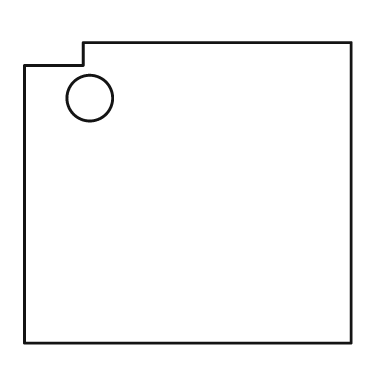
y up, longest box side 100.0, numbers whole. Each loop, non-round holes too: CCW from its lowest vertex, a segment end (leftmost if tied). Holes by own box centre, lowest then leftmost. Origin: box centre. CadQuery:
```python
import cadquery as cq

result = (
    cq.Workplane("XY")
    .moveTo(-50.0, -46.0)
    .lineTo(50.0, -46.0)
    .lineTo(50.0, 46.0)
    .lineTo(-32.0, 46.0)
    .lineTo(-32.0, 39.0)
    .lineTo(-50.0, 39.0)
    .close()
    .moveTo(-30.0, 29.0)
    .circle(7.0)
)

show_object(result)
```